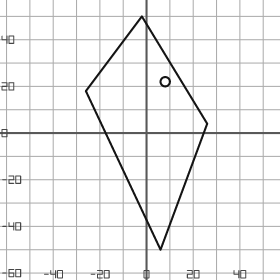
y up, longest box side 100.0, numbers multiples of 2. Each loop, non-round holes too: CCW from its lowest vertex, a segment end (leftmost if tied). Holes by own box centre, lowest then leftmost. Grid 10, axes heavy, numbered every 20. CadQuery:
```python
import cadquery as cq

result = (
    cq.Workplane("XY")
    .moveTo(6.0, -50.0)
    .lineTo(26.0, 4.0)
    .lineTo(-2.0, 50.0)
    .lineTo(-26.0, 18.0)
    .close()
    .moveTo(8.0, 22.0)
    .circle(2.0)
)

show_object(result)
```